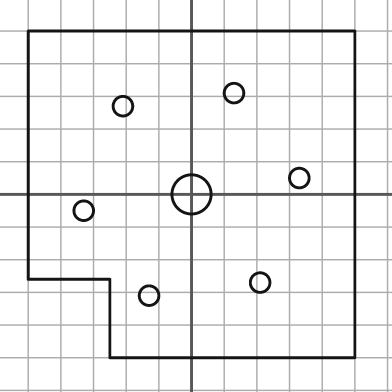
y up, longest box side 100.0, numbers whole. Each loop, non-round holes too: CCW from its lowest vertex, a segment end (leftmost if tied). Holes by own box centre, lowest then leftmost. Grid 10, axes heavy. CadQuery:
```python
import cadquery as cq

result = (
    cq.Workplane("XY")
    .moveTo(-25.0, -50.0)
    .lineTo(50.0, -50.0)
    .lineTo(50.0, 50.0)
    .lineTo(-50.0, 50.0)
    .lineTo(-50.0, -26.0)
    .lineTo(-25.0, -26.0)
    .close()
    .moveTo(-13.0, -31.0)
    .circle(3.0)
    .moveTo(21.0, -27.0)
    .circle(3.0)
    .moveTo(-33.0, -5.0)
    .circle(3.0)
    .moveTo(0.0, 0.0)
    .circle(6.0)
    .moveTo(33.0, 5.0)
    .circle(3.0)
    .moveTo(-21.0, 27.0)
    .circle(3.0)
    .moveTo(13.0, 31.0)
    .circle(3.0)
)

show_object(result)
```